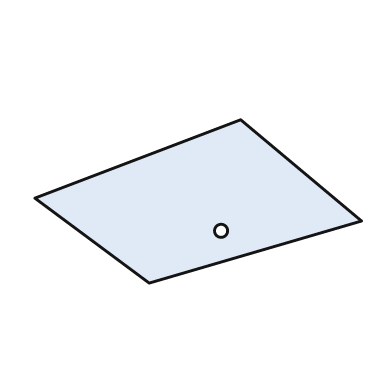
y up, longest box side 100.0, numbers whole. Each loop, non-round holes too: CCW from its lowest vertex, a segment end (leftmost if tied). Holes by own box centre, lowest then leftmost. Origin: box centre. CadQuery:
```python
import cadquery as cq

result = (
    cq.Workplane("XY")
    .moveTo(-15.0, -25.0)
    .lineTo(50.0, -6.0)
    .lineTo(13.0, 25.0)
    .lineTo(-50.0, 1.0)
    .close()
    .moveTo(7.0, -9.0)
    .circle(2.0)
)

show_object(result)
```